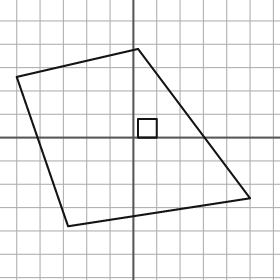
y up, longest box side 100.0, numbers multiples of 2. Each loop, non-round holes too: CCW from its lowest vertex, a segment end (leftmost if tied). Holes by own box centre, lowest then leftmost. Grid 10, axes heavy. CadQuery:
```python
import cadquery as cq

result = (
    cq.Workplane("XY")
    .moveTo(-28.0, -38.0)
    .lineTo(50.0, -26.0)
    .lineTo(2.0, 38.0)
    .lineTo(-50.0, 26.0)
    .close()
    .moveTo(2.0, 0.0)
    .lineTo(10.0, 0.0)
    .lineTo(10.0, 8.0)
    .lineTo(2.0, 8.0)
    .close()
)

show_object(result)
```